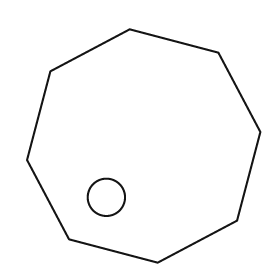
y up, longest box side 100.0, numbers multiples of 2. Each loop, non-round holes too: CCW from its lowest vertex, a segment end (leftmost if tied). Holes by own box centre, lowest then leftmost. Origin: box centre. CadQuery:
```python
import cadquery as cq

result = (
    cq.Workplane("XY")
    .moveTo(6.0, -50.0)
    .lineTo(40.0, -32.0)
    .lineTo(50.0, 6.0)
    .lineTo(32.0, 40.0)
    .lineTo(-6.0, 50.0)
    .lineTo(-40.0, 32.0)
    .lineTo(-50.0, -6.0)
    .lineTo(-32.0, -40.0)
    .close()
    .moveTo(-16.0, -22.0)
    .circle(8.0)
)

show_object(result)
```